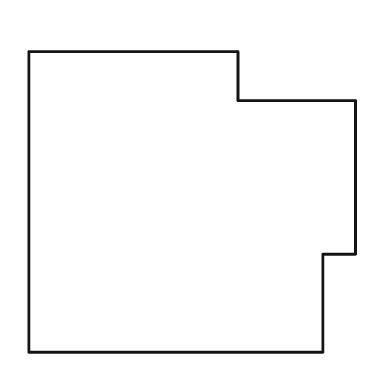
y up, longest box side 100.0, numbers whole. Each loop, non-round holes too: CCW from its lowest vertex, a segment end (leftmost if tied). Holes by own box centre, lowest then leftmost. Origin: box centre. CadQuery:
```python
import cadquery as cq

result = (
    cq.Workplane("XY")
    .moveTo(-50.0, -46.0)
    .lineTo(40.0, -46.0)
    .lineTo(40.0, -16.0)
    .lineTo(50.0, -16.0)
    .lineTo(50.0, 31.0)
    .lineTo(14.0, 31.0)
    .lineTo(14.0, 46.0)
    .lineTo(-50.0, 46.0)
    .close()
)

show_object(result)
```